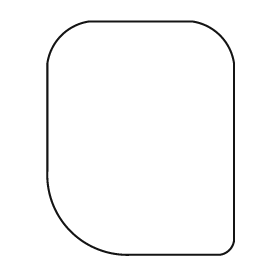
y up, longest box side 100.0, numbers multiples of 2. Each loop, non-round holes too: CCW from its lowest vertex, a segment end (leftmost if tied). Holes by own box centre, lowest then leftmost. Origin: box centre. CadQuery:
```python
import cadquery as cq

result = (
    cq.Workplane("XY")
    .moveTo(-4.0, -50.0)
    .lineTo(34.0, -50.0)
    .threePointArc((38.0, -48.0), (40.0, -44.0))
    .lineTo(40.0, 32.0)
    .threePointArc((34.0, 44.0), (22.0, 50.0))
    .lineTo(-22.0, 50.0)
    .threePointArc((-34.0, 44.0), (-40.0, 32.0))
    .lineTo(-40.0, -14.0)
    .threePointArc((-30.0, -40.0), (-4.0, -50.0))
    .close()
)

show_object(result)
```